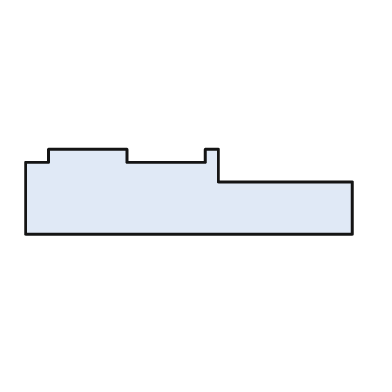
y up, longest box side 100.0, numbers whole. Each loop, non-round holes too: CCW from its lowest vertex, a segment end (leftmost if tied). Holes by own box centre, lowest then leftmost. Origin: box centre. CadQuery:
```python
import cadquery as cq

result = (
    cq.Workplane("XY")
    .moveTo(-50.0, -13.0)
    .lineTo(50.0, -13.0)
    .lineTo(50.0, 3.0)
    .lineTo(9.0, 3.0)
    .lineTo(9.0, 13.0)
    .lineTo(5.0, 13.0)
    .lineTo(5.0, 9.0)
    .lineTo(-19.0, 9.0)
    .lineTo(-19.0, 13.0)
    .lineTo(-43.0, 13.0)
    .lineTo(-43.0, 9.0)
    .lineTo(-50.0, 9.0)
    .close()
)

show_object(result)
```